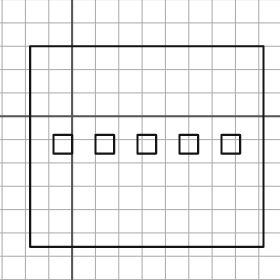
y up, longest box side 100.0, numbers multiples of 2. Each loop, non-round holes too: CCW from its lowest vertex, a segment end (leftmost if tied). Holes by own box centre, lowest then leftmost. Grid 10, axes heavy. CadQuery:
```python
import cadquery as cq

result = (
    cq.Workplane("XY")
    .moveTo(-18.0, -56.0)
    .lineTo(82.0, -56.0)
    .lineTo(82.0, 30.0)
    .lineTo(-18.0, 30.0)
    .close()
    .moveTo(-8.0, -16.0)
    .lineTo(0.0, -16.0)
    .lineTo(0.0, -8.0)
    .lineTo(-8.0, -8.0)
    .close()
    .moveTo(10.0, -16.0)
    .lineTo(18.0, -16.0)
    .lineTo(18.0, -8.0)
    .lineTo(10.0, -8.0)
    .close()
    .moveTo(28.0, -16.0)
    .lineTo(36.0, -16.0)
    .lineTo(36.0, -8.0)
    .lineTo(28.0, -8.0)
    .close()
    .moveTo(46.0, -16.0)
    .lineTo(54.0, -16.0)
    .lineTo(54.0, -8.0)
    .lineTo(46.0, -8.0)
    .close()
    .moveTo(64.0, -16.0)
    .lineTo(72.0, -16.0)
    .lineTo(72.0, -8.0)
    .lineTo(64.0, -8.0)
    .close()
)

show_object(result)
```